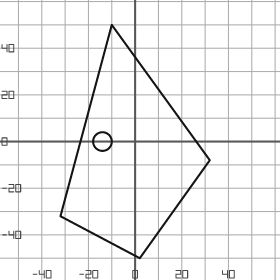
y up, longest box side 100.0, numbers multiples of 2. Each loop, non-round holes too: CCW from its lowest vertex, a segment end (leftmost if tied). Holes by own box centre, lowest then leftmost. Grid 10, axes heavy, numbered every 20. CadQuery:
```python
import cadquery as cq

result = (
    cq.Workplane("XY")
    .moveTo(2.0, -50.0)
    .lineTo(32.0, -8.0)
    .lineTo(-10.0, 50.0)
    .lineTo(-32.0, -32.0)
    .close()
    .moveTo(-14.0, 0.0)
    .circle(4.0)
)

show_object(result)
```